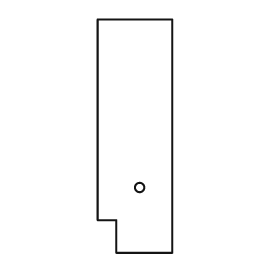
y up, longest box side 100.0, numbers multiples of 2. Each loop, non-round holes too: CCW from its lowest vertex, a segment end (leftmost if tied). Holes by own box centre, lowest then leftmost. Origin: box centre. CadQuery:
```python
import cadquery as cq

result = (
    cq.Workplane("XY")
    .moveTo(-8.0, -50.0)
    .lineTo(16.0, -50.0)
    .lineTo(16.0, 50.0)
    .lineTo(-16.0, 50.0)
    .lineTo(-16.0, -36.0)
    .lineTo(-8.0, -36.0)
    .close()
    .moveTo(2.0, -22.0)
    .circle(2.0)
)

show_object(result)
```